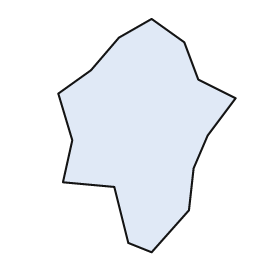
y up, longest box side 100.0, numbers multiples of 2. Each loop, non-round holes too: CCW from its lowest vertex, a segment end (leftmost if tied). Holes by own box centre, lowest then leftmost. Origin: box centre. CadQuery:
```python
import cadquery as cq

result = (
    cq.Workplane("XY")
    .moveTo(2.0, -50.0)
    .lineTo(18.0, -32.0)
    .lineTo(20.0, -14.0)
    .lineTo(26.0, 0.0)
    .lineTo(38.0, 16.0)
    .lineTo(22.0, 24.0)
    .lineTo(16.0, 40.0)
    .lineTo(2.0, 50.0)
    .lineTo(-12.0, 42.0)
    .lineTo(-24.0, 28.0)
    .lineTo(-38.0, 18.0)
    .lineTo(-32.0, -2.0)
    .lineTo(-36.0, -20.0)
    .lineTo(-14.0, -22.0)
    .lineTo(-8.0, -46.0)
    .close()
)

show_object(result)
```